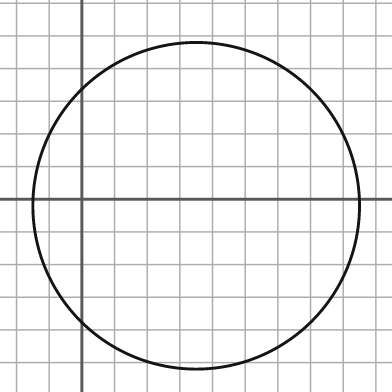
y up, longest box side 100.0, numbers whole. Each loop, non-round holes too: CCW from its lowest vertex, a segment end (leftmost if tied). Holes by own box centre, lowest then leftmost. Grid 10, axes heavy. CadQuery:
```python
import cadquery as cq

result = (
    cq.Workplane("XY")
    .moveTo(35.0, -2.0)
    .circle(50.0)
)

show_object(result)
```